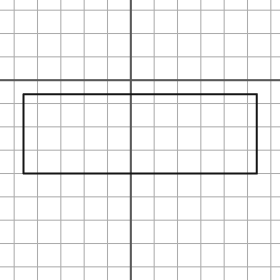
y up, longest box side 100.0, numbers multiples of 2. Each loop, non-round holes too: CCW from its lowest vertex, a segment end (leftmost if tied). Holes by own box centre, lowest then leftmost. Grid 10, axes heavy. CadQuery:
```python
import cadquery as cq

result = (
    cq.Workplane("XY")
    .moveTo(-46.0, -40.0)
    .lineTo(54.0, -40.0)
    .lineTo(54.0, -6.0)
    .lineTo(-46.0, -6.0)
    .close()
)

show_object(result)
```